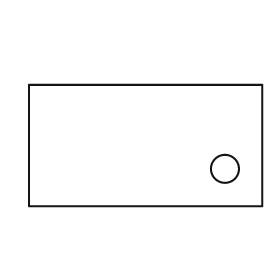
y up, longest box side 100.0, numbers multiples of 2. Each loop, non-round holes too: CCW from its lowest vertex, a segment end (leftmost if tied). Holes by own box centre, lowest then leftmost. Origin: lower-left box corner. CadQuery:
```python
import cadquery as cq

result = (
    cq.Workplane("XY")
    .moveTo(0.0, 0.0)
    .lineTo(100.0, 0.0)
    .lineTo(100.0, 52.0)
    .lineTo(0.0, 52.0)
    .close()
    .moveTo(84.0, 16.0)
    .circle(6.0)
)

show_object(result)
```